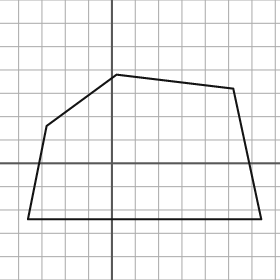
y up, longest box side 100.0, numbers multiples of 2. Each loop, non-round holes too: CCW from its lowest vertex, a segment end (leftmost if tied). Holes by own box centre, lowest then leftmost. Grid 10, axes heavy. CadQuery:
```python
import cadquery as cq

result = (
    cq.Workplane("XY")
    .moveTo(-36.0, -24.0)
    .lineTo(64.0, -24.0)
    .lineTo(52.0, 32.0)
    .lineTo(2.0, 38.0)
    .lineTo(-28.0, 16.0)
    .close()
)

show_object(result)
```